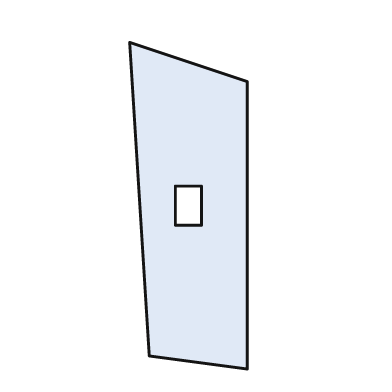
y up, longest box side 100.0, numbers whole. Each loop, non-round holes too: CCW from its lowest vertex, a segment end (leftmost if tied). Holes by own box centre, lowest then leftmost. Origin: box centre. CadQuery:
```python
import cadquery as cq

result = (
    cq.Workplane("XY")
    .moveTo(18.0, -50.0)
    .lineTo(18.0, 38.0)
    .lineTo(-18.0, 50.0)
    .lineTo(-12.0, -46.0)
    .close()
    .moveTo(-4.0, -6.0)
    .lineTo(4.0, -6.0)
    .lineTo(4.0, 6.0)
    .lineTo(-4.0, 6.0)
    .close()
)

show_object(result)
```